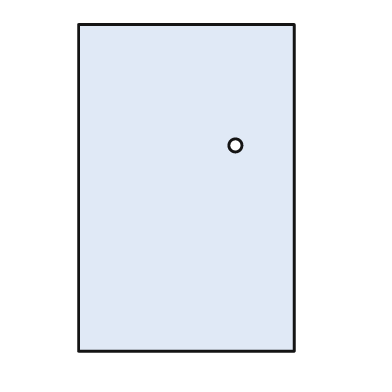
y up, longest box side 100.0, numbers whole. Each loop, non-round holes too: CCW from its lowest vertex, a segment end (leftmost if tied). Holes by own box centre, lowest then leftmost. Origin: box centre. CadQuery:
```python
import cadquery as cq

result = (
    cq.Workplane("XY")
    .moveTo(-33.0, -50.0)
    .lineTo(33.0, -50.0)
    .lineTo(33.0, 50.0)
    .lineTo(-33.0, 50.0)
    .close()
    .moveTo(15.0, 13.0)
    .circle(2.0)
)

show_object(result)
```